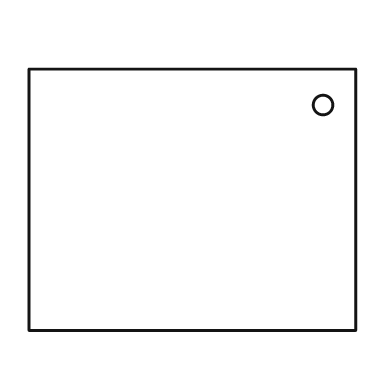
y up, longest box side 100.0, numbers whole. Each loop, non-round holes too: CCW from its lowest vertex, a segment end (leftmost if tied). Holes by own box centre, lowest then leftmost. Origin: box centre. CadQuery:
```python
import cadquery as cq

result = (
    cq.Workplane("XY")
    .moveTo(-50.0, -40.0)
    .lineTo(50.0, -40.0)
    .lineTo(50.0, 40.0)
    .lineTo(-50.0, 40.0)
    .close()
    .moveTo(40.0, 29.0)
    .circle(3.0)
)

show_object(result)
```